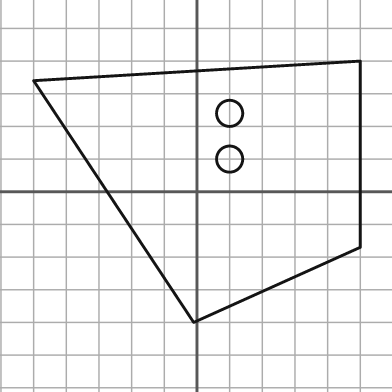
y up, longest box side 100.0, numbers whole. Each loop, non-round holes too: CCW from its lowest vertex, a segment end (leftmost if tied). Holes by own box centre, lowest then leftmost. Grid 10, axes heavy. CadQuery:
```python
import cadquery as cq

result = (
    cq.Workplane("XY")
    .moveTo(-1.0, -40.0)
    .lineTo(50.0, -17.0)
    .lineTo(50.0, 40.0)
    .lineTo(-50.0, 34.0)
    .close()
    .moveTo(10.0, 10.0)
    .circle(4.0)
    .moveTo(10.0, 24.0)
    .circle(4.0)
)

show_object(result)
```